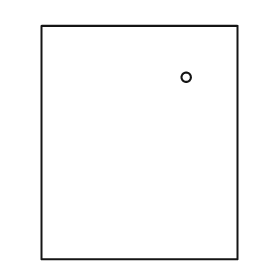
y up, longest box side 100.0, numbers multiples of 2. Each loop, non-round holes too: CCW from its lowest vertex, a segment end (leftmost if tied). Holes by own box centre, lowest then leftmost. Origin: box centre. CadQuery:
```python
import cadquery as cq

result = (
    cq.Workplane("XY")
    .moveTo(-42.0, -50.0)
    .lineTo(42.0, -50.0)
    .lineTo(42.0, 50.0)
    .lineTo(-42.0, 50.0)
    .close()
    .moveTo(20.0, 28.0)
    .circle(2.0)
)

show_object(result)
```